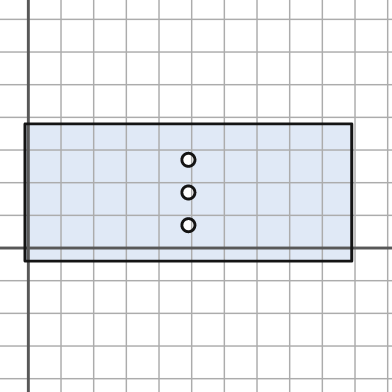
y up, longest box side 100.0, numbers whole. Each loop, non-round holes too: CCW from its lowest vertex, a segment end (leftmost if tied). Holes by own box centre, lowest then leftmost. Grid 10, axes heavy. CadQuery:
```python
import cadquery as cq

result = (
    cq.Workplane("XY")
    .moveTo(-1.0, -4.0)
    .lineTo(99.0, -4.0)
    .lineTo(99.0, 38.0)
    .lineTo(-1.0, 38.0)
    .close()
    .moveTo(49.0, 7.0)
    .circle(2.0)
    .moveTo(49.0, 17.0)
    .circle(2.0)
    .moveTo(49.0, 27.0)
    .circle(2.0)
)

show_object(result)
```